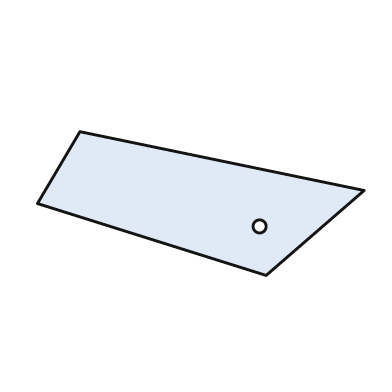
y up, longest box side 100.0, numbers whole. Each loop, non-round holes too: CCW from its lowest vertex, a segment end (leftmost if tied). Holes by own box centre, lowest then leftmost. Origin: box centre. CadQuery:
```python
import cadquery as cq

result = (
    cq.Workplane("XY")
    .moveTo(20.0, -22.0)
    .lineTo(50.0, 4.0)
    .lineTo(-37.0, 22.0)
    .lineTo(-50.0, 0.0)
    .close()
    .moveTo(18.0, -7.0)
    .circle(2.0)
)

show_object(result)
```